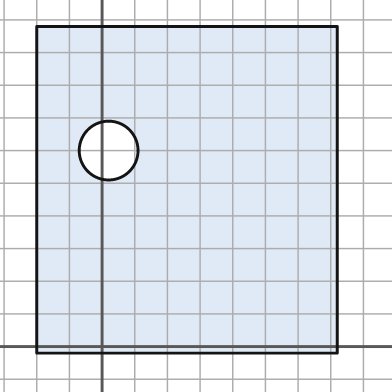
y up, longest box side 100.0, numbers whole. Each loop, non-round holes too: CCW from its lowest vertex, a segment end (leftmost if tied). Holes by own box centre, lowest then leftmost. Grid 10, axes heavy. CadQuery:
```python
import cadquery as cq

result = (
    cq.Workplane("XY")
    .moveTo(-20.0, -2.0)
    .lineTo(72.0, -2.0)
    .lineTo(72.0, 98.0)
    .lineTo(-20.0, 98.0)
    .close()
    .moveTo(2.0, 60.0)
    .circle(9.0)
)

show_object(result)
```